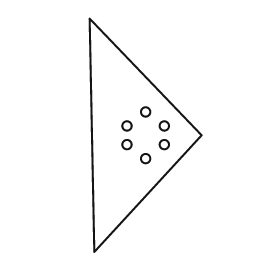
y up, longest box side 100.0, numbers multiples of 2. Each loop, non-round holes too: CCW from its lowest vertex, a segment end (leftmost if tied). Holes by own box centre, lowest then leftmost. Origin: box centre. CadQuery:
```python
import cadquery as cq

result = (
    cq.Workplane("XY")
    .moveTo(-22.0, -50.0)
    .lineTo(24.0, 0.0)
    .lineTo(-24.0, 50.0)
    .close()
    .moveTo(0.0, -10.0)
    .circle(2.0)
    .moveTo(-8.0, -4.0)
    .circle(2.0)
    .moveTo(8.0, -4.0)
    .circle(2.0)
    .moveTo(-8.0, 4.0)
    .circle(2.0)
    .moveTo(8.0, 4.0)
    .circle(2.0)
    .moveTo(0.0, 10.0)
    .circle(2.0)
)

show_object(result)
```